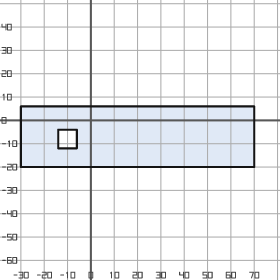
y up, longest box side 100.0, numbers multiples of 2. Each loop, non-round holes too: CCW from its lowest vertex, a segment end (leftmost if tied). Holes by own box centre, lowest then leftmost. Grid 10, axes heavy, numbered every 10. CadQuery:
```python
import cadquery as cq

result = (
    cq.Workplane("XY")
    .moveTo(-30.0, -20.0)
    .lineTo(70.0, -20.0)
    .lineTo(70.0, 6.0)
    .lineTo(-30.0, 6.0)
    .close()
    .moveTo(-14.0, -12.0)
    .lineTo(-6.0, -12.0)
    .lineTo(-6.0, -4.0)
    .lineTo(-14.0, -4.0)
    .close()
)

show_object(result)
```